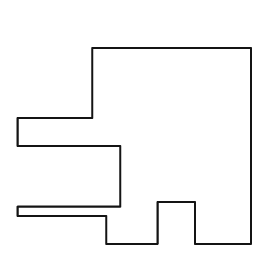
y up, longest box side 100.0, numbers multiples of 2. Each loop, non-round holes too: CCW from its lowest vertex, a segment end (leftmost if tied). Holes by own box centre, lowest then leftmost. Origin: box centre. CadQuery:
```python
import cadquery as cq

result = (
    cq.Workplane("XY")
    .moveTo(-12.0, -42.0)
    .lineTo(10.0, -42.0)
    .lineTo(10.0, -24.0)
    .lineTo(26.0, -24.0)
    .lineTo(26.0, -42.0)
    .lineTo(50.0, -42.0)
    .lineTo(50.0, 42.0)
    .lineTo(-18.0, 42.0)
    .lineTo(-18.0, 12.0)
    .lineTo(-50.0, 12.0)
    .lineTo(-50.0, 0.0)
    .lineTo(-6.0, 0.0)
    .lineTo(-6.0, -26.0)
    .lineTo(-50.0, -26.0)
    .lineTo(-50.0, -30.0)
    .lineTo(-12.0, -30.0)
    .close()
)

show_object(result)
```